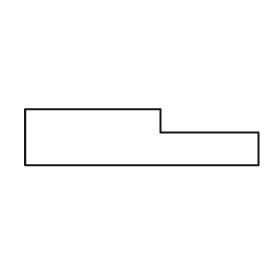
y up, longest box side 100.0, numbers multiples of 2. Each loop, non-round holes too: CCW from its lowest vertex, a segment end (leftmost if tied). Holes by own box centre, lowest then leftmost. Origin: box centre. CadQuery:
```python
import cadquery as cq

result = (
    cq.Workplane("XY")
    .moveTo(-50.0, -12.0)
    .lineTo(50.0, -12.0)
    .lineTo(50.0, 2.0)
    .lineTo(8.0, 2.0)
    .lineTo(8.0, 12.0)
    .lineTo(-50.0, 12.0)
    .close()
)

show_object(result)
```